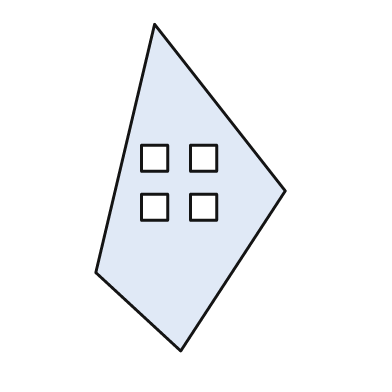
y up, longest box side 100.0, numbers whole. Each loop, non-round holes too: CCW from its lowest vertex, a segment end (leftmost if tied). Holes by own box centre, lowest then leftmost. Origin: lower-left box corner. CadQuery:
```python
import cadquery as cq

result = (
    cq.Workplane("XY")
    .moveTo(26.0, 0.0)
    .lineTo(58.0, 49.0)
    .lineTo(18.0, 100.0)
    .lineTo(0.0, 24.0)
    .close()
    .moveTo(14.0, 40.0)
    .lineTo(22.0, 40.0)
    .lineTo(22.0, 48.0)
    .lineTo(14.0, 48.0)
    .close()
    .moveTo(29.0, 40.0)
    .lineTo(37.0, 40.0)
    .lineTo(37.0, 48.0)
    .lineTo(29.0, 48.0)
    .close()
    .moveTo(14.0, 55.0)
    .lineTo(22.0, 55.0)
    .lineTo(22.0, 63.0)
    .lineTo(14.0, 63.0)
    .close()
    .moveTo(29.0, 55.0)
    .lineTo(37.0, 55.0)
    .lineTo(37.0, 63.0)
    .lineTo(29.0, 63.0)
    .close()
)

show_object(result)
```